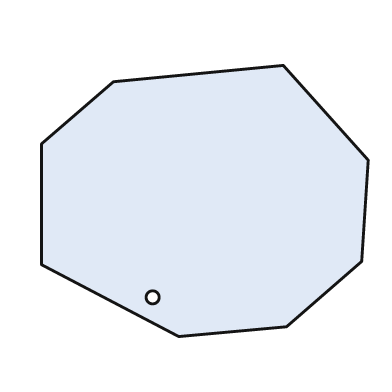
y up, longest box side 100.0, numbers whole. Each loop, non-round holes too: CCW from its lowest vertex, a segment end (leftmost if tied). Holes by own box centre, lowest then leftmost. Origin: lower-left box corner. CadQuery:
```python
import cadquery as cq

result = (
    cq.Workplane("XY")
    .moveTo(42.0, 0.0)
    .lineTo(75.0, 3.0)
    .lineTo(98.0, 23.0)
    .lineTo(100.0, 54.0)
    .lineTo(74.0, 83.0)
    .lineTo(22.0, 78.0)
    .lineTo(0.0, 59.0)
    .lineTo(0.0, 22.0)
    .close()
    .moveTo(34.0, 12.0)
    .circle(2.0)
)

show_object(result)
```